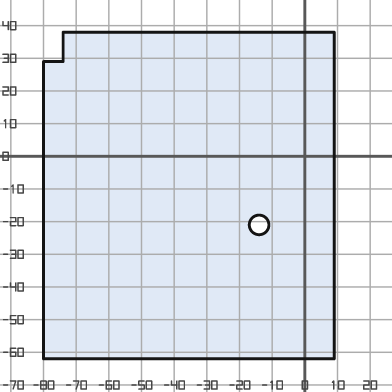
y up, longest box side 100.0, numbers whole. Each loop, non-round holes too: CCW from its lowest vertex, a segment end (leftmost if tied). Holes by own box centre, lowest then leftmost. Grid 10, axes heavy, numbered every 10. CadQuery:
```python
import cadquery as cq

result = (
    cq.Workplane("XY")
    .moveTo(-80.0, -62.0)
    .lineTo(9.0, -62.0)
    .lineTo(9.0, 38.0)
    .lineTo(-74.0, 38.0)
    .lineTo(-74.0, 29.0)
    .lineTo(-80.0, 29.0)
    .close()
    .moveTo(-14.0, -21.0)
    .circle(3.0)
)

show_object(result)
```